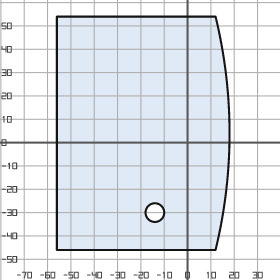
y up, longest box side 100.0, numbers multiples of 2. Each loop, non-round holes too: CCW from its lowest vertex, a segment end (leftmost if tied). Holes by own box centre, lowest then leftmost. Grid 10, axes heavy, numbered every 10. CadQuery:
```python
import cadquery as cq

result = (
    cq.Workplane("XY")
    .moveTo(-56.0, -46.0)
    .lineTo(12.0, -46.0)
    .threePointArc((18.0, 4.0), (12.0, 54.0))
    .lineTo(-56.0, 54.0)
    .close()
    .moveTo(-14.0, -30.0)
    .circle(4.0)
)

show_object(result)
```